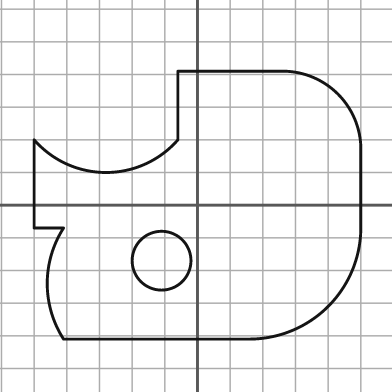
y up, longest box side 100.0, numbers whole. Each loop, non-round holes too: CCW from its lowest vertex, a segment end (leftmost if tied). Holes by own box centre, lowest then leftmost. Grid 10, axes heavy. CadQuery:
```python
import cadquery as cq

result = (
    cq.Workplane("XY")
    .moveTo(-41.0, -41.0)
    .lineTo(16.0, -41.0)
    .threePointArc((40.0, -31.0), (50.0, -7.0))
    .lineTo(50.0, 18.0)
    .threePointArc((43.0, 34.0), (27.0, 41.0))
    .lineTo(-6.0, 41.0)
    .lineTo(-6.0, 20.0)
    .threePointArc((-28.0, 10.0), (-50.0, 20.0))
    .lineTo(-50.0, -7.0)
    .lineTo(-41.0, -7.0)
    .threePointArc((-46.0, -24.0), (-41.0, -41.0))
    .close()
    .moveTo(-11.0, -17.0)
    .circle(9.0)
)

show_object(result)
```